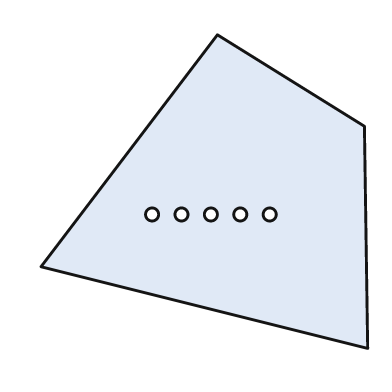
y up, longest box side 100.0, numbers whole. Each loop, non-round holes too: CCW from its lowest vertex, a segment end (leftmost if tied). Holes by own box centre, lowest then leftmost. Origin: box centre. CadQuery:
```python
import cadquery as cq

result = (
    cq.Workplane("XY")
    .moveTo(50.0, -48.0)
    .lineTo(49.0, 20.0)
    .lineTo(4.0, 48.0)
    .lineTo(-50.0, -23.0)
    .close()
    .moveTo(-16.0, -7.0)
    .circle(2.0)
    .moveTo(-7.0, -7.0)
    .circle(2.0)
    .moveTo(2.0, -7.0)
    .circle(2.0)
    .moveTo(11.0, -7.0)
    .circle(2.0)
    .moveTo(20.0, -7.0)
    .circle(2.0)
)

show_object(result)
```